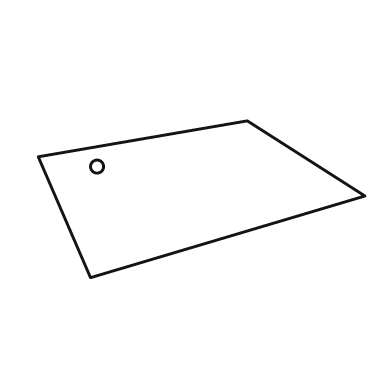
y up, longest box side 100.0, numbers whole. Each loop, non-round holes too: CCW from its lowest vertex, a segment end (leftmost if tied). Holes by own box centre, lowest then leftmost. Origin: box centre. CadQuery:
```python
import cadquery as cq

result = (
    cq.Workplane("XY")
    .moveTo(-34.0, -24.0)
    .lineTo(50.0, 1.0)
    .lineTo(14.0, 24.0)
    .lineTo(-50.0, 13.0)
    .close()
    .moveTo(-32.0, 10.0)
    .circle(2.0)
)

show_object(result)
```